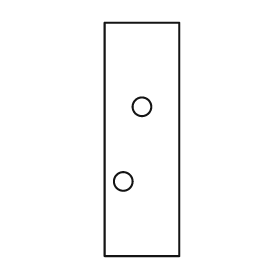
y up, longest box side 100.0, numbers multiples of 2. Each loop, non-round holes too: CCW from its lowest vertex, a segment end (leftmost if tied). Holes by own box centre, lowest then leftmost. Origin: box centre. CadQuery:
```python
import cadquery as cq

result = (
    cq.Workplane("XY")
    .moveTo(-16.0, -50.0)
    .lineTo(16.0, -50.0)
    .lineTo(16.0, 50.0)
    .lineTo(-16.0, 50.0)
    .close()
    .moveTo(-8.0, -18.0)
    .circle(4.0)
    .moveTo(0.0, 14.0)
    .circle(4.0)
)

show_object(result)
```